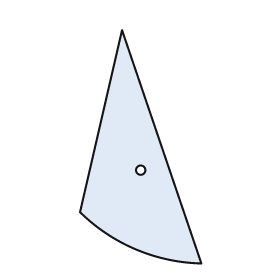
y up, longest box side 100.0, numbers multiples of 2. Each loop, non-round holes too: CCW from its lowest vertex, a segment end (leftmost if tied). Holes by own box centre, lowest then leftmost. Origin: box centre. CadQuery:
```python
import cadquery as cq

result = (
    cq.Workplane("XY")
    .moveTo(26.0, -50.0)
    .lineTo(-8.0, 50.0)
    .lineTo(-26.0, -28.0)
    .threePointArc((-2.0, -44.0), (26.0, -50.0))
    .close()
    .moveTo(0.0, -10.0)
    .circle(2.0)
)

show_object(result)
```